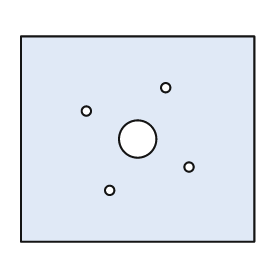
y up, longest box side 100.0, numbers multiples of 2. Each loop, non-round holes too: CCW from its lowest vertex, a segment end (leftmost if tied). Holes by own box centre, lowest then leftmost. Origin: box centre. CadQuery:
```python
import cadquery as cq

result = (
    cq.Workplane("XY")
    .moveTo(-50.0, -44.0)
    .lineTo(50.0, -44.0)
    .lineTo(50.0, 44.0)
    .lineTo(-50.0, 44.0)
    .close()
    .moveTo(-12.0, -22.0)
    .circle(2.0)
    .moveTo(22.0, -12.0)
    .circle(2.0)
    .moveTo(0.0, 0.0)
    .circle(8.0)
    .moveTo(-22.0, 12.0)
    .circle(2.0)
    .moveTo(12.0, 22.0)
    .circle(2.0)
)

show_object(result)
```